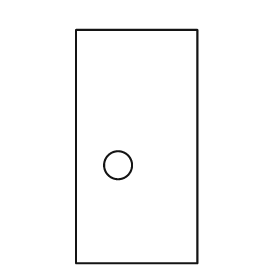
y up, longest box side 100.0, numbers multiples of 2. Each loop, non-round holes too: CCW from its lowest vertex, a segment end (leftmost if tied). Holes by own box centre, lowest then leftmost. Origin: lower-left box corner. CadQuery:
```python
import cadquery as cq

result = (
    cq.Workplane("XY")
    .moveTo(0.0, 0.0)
    .lineTo(52.0, 0.0)
    .lineTo(52.0, 100.0)
    .lineTo(0.0, 100.0)
    .close()
    .moveTo(18.0, 42.0)
    .circle(6.0)
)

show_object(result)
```